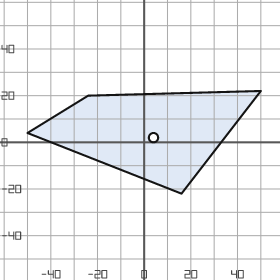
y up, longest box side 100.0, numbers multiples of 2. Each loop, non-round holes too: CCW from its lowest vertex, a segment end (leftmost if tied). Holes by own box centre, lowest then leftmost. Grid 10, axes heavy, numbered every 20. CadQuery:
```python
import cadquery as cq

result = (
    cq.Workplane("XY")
    .moveTo(16.0, -22.0)
    .lineTo(50.0, 22.0)
    .lineTo(-24.0, 20.0)
    .lineTo(-50.0, 4.0)
    .close()
    .moveTo(4.0, 2.0)
    .circle(2.0)
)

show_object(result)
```